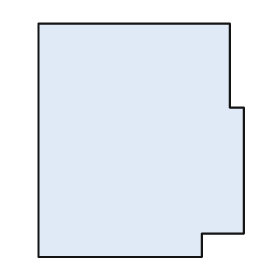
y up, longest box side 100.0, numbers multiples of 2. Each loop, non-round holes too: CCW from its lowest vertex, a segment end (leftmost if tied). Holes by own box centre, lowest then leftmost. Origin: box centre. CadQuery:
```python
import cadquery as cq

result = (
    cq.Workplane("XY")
    .moveTo(-44.0, -50.0)
    .lineTo(26.0, -50.0)
    .lineTo(26.0, -40.0)
    .lineTo(44.0, -40.0)
    .lineTo(44.0, 14.0)
    .lineTo(38.0, 14.0)
    .lineTo(38.0, 50.0)
    .lineTo(-44.0, 50.0)
    .close()
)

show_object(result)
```